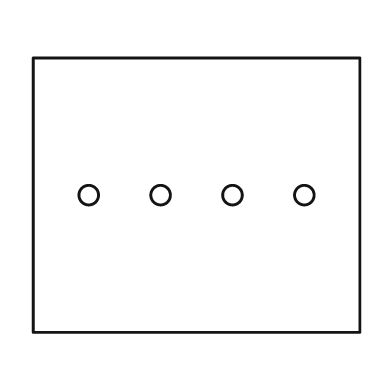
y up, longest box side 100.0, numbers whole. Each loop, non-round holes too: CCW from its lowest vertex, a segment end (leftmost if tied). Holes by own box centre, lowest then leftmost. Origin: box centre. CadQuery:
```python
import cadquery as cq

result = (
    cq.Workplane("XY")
    .moveTo(-50.0, -42.0)
    .lineTo(50.0, -42.0)
    .lineTo(50.0, 42.0)
    .lineTo(-50.0, 42.0)
    .close()
    .moveTo(-33.0, 0.0)
    .circle(3.0)
    .moveTo(-11.0, 0.0)
    .circle(3.0)
    .moveTo(11.0, 0.0)
    .circle(3.0)
    .moveTo(33.0, 0.0)
    .circle(3.0)
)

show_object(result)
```